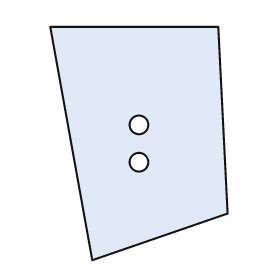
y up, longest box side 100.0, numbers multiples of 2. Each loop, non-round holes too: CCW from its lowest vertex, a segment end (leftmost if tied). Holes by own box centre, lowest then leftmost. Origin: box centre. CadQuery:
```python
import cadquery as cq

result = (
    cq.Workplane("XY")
    .moveTo(-20.0, -50.0)
    .lineTo(38.0, -30.0)
    .lineTo(34.0, 50.0)
    .lineTo(-38.0, 50.0)
    .close()
    .moveTo(0.0, -8.0)
    .circle(4.0)
    .moveTo(0.0, 8.0)
    .circle(4.0)
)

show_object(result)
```